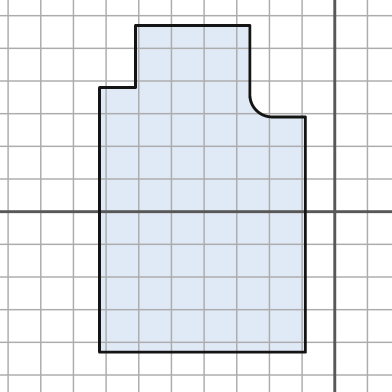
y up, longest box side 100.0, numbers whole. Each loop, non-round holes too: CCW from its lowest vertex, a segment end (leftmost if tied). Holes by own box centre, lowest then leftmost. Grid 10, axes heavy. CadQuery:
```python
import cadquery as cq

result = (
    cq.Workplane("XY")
    .moveTo(-72.0, -43.0)
    .lineTo(-9.0, -43.0)
    .lineTo(-9.0, 29.0)
    .lineTo(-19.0, 29.0)
    .threePointArc((-24.0, 31.0), (-26.0, 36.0))
    .lineTo(-26.0, 57.0)
    .lineTo(-61.0, 57.0)
    .lineTo(-61.0, 38.0)
    .lineTo(-72.0, 38.0)
    .close()
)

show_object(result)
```